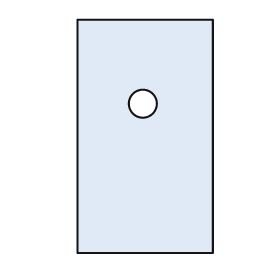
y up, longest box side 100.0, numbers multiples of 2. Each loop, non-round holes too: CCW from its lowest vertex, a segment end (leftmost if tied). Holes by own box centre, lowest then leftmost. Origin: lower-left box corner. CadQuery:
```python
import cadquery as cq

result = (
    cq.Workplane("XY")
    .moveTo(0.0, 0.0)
    .lineTo(58.0, 0.0)
    .lineTo(58.0, 100.0)
    .lineTo(0.0, 100.0)
    .close()
    .moveTo(28.0, 64.0)
    .circle(6.0)
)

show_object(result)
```